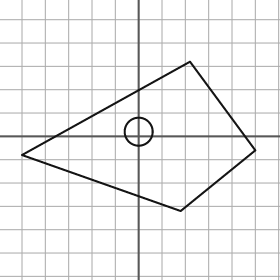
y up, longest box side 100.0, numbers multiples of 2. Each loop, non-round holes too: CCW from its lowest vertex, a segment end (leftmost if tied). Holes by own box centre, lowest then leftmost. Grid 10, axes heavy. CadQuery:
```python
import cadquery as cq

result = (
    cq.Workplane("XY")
    .moveTo(18.0, -32.0)
    .lineTo(50.0, -6.0)
    .lineTo(22.0, 32.0)
    .lineTo(-50.0, -8.0)
    .close()
    .moveTo(0.0, 2.0)
    .circle(6.0)
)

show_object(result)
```